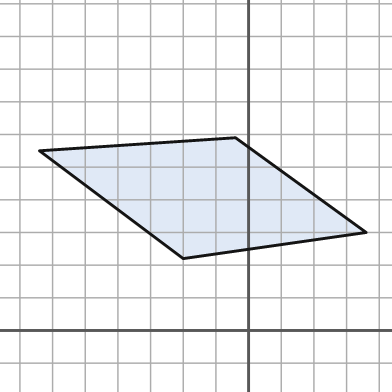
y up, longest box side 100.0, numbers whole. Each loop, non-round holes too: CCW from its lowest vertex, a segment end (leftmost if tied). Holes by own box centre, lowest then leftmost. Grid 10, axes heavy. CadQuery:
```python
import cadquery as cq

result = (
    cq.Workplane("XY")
    .moveTo(-20.0, 22.0)
    .lineTo(36.0, 30.0)
    .lineTo(-4.0, 59.0)
    .lineTo(-64.0, 55.0)
    .close()
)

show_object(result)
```